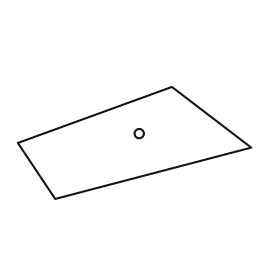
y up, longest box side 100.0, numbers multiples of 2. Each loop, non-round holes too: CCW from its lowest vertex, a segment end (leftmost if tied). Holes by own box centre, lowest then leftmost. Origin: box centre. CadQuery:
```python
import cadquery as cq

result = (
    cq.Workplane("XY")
    .moveTo(-34.0, -24.0)
    .lineTo(50.0, -2.0)
    .lineTo(16.0, 24.0)
    .lineTo(-50.0, 0.0)
    .close()
    .moveTo(2.0, 4.0)
    .circle(2.0)
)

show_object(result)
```